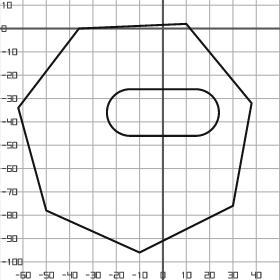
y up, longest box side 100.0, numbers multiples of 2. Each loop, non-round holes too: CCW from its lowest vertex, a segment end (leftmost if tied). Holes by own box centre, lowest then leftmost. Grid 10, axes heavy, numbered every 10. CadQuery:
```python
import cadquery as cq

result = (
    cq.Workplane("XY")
    .moveTo(-10.0, -96.0)
    .lineTo(30.0, -76.0)
    .lineTo(38.0, -32.0)
    .lineTo(10.0, 2.0)
    .lineTo(-36.0, 0.0)
    .lineTo(-62.0, -34.0)
    .lineTo(-50.0, -78.0)
    .close()
    .moveTo(-14.0, -46.0)
    .lineTo(14.0, -46.0)
    .threePointArc((24.0, -36.0), (14.0, -26.0))
    .lineTo(-14.0, -26.0)
    .threePointArc((-24.0, -36.0), (-14.0, -46.0))
    .close()
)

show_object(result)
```